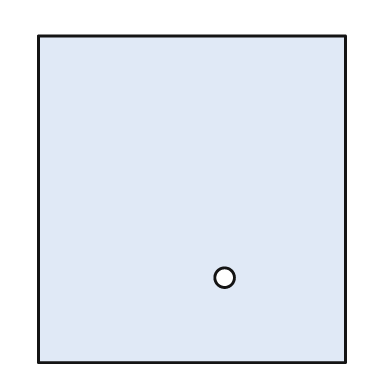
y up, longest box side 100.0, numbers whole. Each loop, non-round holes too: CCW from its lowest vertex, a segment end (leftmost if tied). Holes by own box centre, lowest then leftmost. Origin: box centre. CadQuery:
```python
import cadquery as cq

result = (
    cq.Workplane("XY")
    .moveTo(-47.0, -50.0)
    .lineTo(47.0, -50.0)
    .lineTo(47.0, 50.0)
    .lineTo(-47.0, 50.0)
    .close()
    .moveTo(10.0, -24.0)
    .circle(3.0)
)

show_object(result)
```